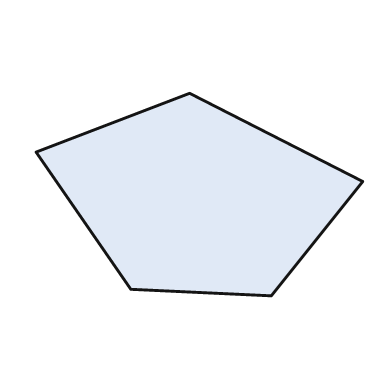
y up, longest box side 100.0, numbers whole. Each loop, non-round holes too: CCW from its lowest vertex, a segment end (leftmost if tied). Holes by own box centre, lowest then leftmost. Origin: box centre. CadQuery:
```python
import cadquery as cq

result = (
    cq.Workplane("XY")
    .moveTo(22.0, -31.0)
    .lineTo(50.0, 4.0)
    .lineTo(-3.0, 31.0)
    .lineTo(-50.0, 13.0)
    .lineTo(-21.0, -29.0)
    .close()
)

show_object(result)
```